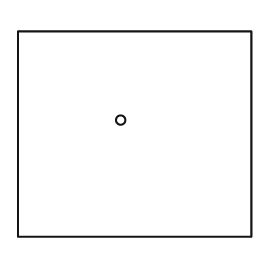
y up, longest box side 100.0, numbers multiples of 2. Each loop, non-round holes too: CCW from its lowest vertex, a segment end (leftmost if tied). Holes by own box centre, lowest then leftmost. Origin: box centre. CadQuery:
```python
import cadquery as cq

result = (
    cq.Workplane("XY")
    .moveTo(-50.0, -44.0)
    .lineTo(50.0, -44.0)
    .lineTo(50.0, 44.0)
    .lineTo(-50.0, 44.0)
    .close()
    .moveTo(-6.0, 6.0)
    .circle(2.0)
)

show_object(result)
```